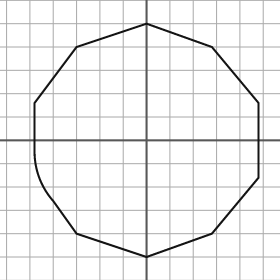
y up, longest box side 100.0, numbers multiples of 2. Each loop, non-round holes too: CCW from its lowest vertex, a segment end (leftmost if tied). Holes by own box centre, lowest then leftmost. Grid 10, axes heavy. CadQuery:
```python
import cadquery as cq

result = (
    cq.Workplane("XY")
    .moveTo(0.0, -50.0)
    .lineTo(28.0, -40.0)
    .lineTo(48.0, -16.0)
    .lineTo(48.0, 16.0)
    .lineTo(28.0, 40.0)
    .lineTo(0.0, 50.0)
    .lineTo(-30.0, 40.0)
    .lineTo(-48.0, 16.0)
    .lineTo(-48.0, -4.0)
    .threePointArc((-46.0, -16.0), (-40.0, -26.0))
    .lineTo(-30.0, -40.0)
    .close()
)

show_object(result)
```